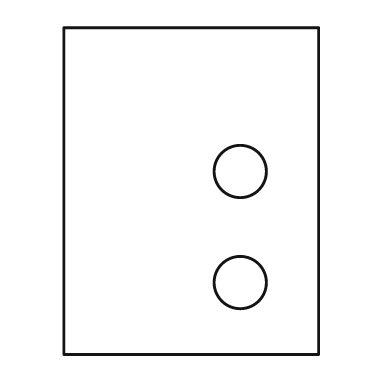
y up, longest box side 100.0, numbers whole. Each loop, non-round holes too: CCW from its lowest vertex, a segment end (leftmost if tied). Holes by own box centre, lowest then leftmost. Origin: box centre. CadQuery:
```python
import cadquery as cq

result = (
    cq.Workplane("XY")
    .moveTo(-39.0, -50.0)
    .lineTo(39.0, -50.0)
    .lineTo(39.0, 50.0)
    .lineTo(-39.0, 50.0)
    .close()
    .moveTo(15.0, -28.0)
    .circle(8.0)
    .moveTo(15.0, 6.0)
    .circle(8.0)
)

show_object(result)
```